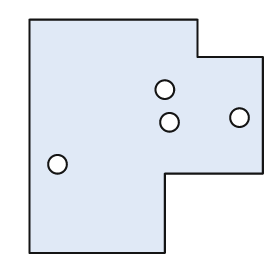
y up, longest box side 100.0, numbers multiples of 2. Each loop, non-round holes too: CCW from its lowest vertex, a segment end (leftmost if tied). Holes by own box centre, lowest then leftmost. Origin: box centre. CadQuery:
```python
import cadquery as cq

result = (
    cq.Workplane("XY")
    .moveTo(-50.0, -50.0)
    .lineTo(8.0, -50.0)
    .lineTo(8.0, -16.0)
    .lineTo(50.0, -16.0)
    .lineTo(50.0, 34.0)
    .lineTo(22.0, 34.0)
    .lineTo(22.0, 50.0)
    .lineTo(-50.0, 50.0)
    .close()
    .moveTo(-38.0, -12.0)
    .circle(4.0)
    .moveTo(10.0, 6.0)
    .circle(4.0)
    .moveTo(40.0, 8.0)
    .circle(4.0)
    .moveTo(8.0, 20.0)
    .circle(4.0)
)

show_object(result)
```